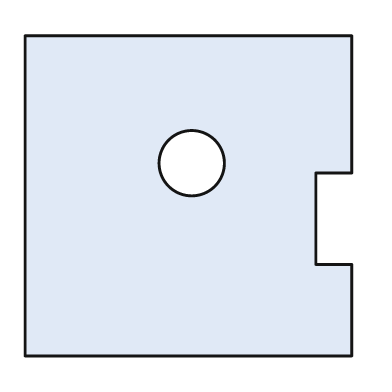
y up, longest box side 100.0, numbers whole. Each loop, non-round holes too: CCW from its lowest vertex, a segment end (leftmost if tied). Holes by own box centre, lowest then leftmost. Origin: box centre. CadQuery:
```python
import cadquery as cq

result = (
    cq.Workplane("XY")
    .moveTo(-50.0, -49.0)
    .lineTo(50.0, -49.0)
    .lineTo(50.0, -21.0)
    .lineTo(39.0, -21.0)
    .lineTo(39.0, 7.0)
    .lineTo(50.0, 7.0)
    .lineTo(50.0, 49.0)
    .lineTo(-50.0, 49.0)
    .close()
    .moveTo(1.0, 10.0)
    .circle(10.0)
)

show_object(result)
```